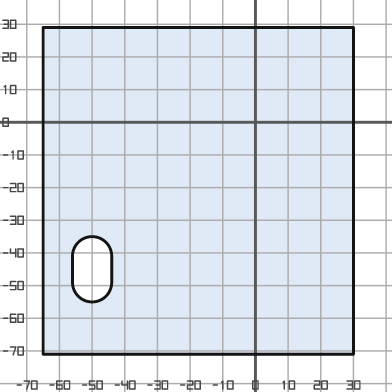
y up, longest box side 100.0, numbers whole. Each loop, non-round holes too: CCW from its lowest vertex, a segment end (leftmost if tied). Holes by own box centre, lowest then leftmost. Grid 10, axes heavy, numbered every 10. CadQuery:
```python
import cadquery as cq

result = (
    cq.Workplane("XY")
    .moveTo(-65.0, -71.0)
    .lineTo(30.0, -71.0)
    .lineTo(30.0, 29.0)
    .lineTo(-65.0, 29.0)
    .close()
    .moveTo(-56.0, -49.0)
    .threePointArc((-50.0, -55.0), (-44.0, -49.0))
    .lineTo(-44.0, -41.0)
    .threePointArc((-50.0, -35.0), (-56.0, -41.0))
    .close()
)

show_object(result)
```